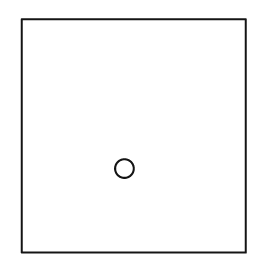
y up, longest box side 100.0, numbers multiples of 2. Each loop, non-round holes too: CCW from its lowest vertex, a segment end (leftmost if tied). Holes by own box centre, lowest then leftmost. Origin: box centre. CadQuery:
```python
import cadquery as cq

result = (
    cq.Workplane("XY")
    .moveTo(-48.0, -50.0)
    .lineTo(48.0, -50.0)
    .lineTo(48.0, 50.0)
    .lineTo(-48.0, 50.0)
    .close()
    .moveTo(-4.0, -14.0)
    .circle(4.0)
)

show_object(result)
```